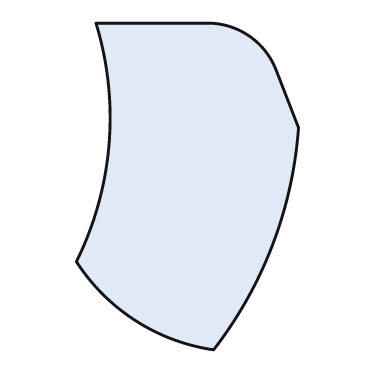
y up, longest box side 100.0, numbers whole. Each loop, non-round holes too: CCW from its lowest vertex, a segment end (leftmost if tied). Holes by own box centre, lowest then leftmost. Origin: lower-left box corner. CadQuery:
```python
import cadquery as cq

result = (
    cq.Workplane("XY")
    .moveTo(42.0, 0.0)
    .threePointArc((60.0, 32.0), (68.0, 68.0))
    .lineTo(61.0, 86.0)
    .threePointArc((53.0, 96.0), (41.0, 100.0))
    .lineTo(6.0, 100.0)
    .threePointArc((10.0, 63.0), (0.0, 27.0))
    .threePointArc((18.0, 9.0), (42.0, 0.0))
    .close()
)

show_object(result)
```